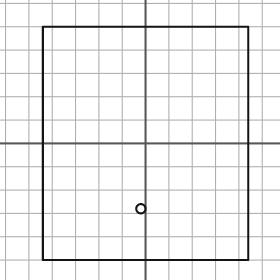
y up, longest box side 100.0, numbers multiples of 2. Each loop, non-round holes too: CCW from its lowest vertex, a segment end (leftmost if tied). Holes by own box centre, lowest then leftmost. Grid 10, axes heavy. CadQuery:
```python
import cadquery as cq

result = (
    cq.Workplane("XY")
    .moveTo(-44.0, -50.0)
    .lineTo(44.0, -50.0)
    .lineTo(44.0, 50.0)
    .lineTo(-44.0, 50.0)
    .close()
    .moveTo(-2.0, -28.0)
    .circle(2.0)
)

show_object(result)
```